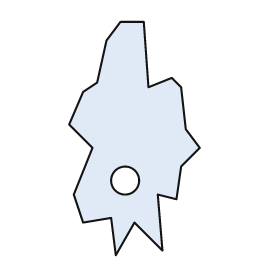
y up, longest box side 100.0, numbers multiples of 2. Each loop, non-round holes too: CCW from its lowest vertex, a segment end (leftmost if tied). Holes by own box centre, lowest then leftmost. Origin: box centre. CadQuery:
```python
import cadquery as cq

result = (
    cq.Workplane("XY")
    .moveTo(-8.0, -50.0)
    .lineTo(0.0, -36.0)
    .lineTo(12.0, -48.0)
    .lineTo(10.0, -24.0)
    .lineTo(18.0, -26.0)
    .lineTo(20.0, -12.0)
    .lineTo(28.0, -4.0)
    .lineTo(22.0, 4.0)
    .lineTo(20.0, 22.0)
    .lineTo(16.0, 26.0)
    .lineTo(6.0, 22.0)
    .lineTo(4.0, 50.0)
    .lineTo(-6.0, 50.0)
    .lineTo(-12.0, 42.0)
    .lineTo(-16.0, 24.0)
    .lineTo(-22.0, 20.0)
    .lineTo(-28.0, 6.0)
    .lineTo(-18.0, -4.0)
    .lineTo(-26.0, -24.0)
    .lineTo(-22.0, -36.0)
    .lineTo(-10.0, -34.0)
    .close()
    .moveTo(-4.0, -18.0)
    .circle(6.0)
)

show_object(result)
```